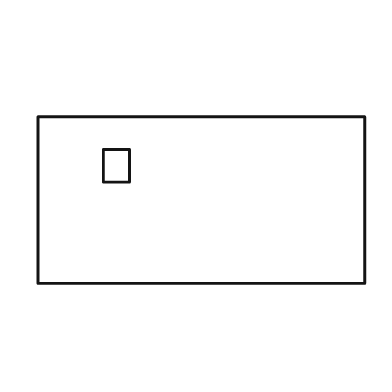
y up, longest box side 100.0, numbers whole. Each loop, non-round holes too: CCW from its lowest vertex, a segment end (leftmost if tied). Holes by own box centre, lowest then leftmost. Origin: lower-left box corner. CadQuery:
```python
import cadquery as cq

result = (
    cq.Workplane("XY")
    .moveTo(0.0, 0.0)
    .lineTo(100.0, 0.0)
    .lineTo(100.0, 51.0)
    .lineTo(0.0, 51.0)
    .close()
    .moveTo(20.0, 31.0)
    .lineTo(28.0, 31.0)
    .lineTo(28.0, 41.0)
    .lineTo(20.0, 41.0)
    .close()
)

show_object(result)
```